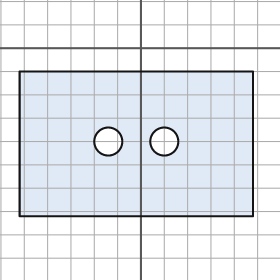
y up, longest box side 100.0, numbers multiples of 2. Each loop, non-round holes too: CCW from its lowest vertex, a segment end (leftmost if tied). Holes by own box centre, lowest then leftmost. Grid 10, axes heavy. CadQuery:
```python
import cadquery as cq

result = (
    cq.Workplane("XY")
    .moveTo(-52.0, -72.0)
    .lineTo(48.0, -72.0)
    .lineTo(48.0, -10.0)
    .lineTo(-52.0, -10.0)
    .close()
    .moveTo(-14.0, -40.0)
    .circle(6.0)
    .moveTo(10.0, -40.0)
    .circle(6.0)
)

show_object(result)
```